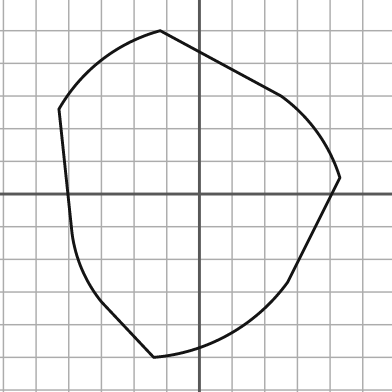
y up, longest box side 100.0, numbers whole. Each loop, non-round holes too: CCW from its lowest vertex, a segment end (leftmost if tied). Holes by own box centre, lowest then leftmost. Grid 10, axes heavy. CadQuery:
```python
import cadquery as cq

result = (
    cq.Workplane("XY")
    .moveTo(-14.0, -50.0)
    .threePointArc((9.0, -43.0), (27.0, -27.0))
    .lineTo(43.0, 5.0)
    .threePointArc((36.0, 19.0), (25.0, 30.0))
    .lineTo(-12.0, 50.0)
    .threePointArc((-30.0, 41.0), (-43.0, 26.0))
    .lineTo(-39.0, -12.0)
    .threePointArc((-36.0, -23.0), (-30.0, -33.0))
    .close()
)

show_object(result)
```